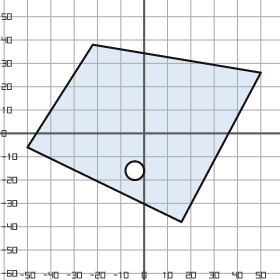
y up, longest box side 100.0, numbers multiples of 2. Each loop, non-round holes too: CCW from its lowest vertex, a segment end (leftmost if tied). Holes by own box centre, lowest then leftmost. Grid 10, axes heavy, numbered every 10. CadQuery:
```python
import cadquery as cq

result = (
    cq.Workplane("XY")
    .moveTo(16.0, -38.0)
    .lineTo(50.0, 26.0)
    .lineTo(-22.0, 38.0)
    .lineTo(-50.0, -6.0)
    .close()
    .moveTo(-4.0, -16.0)
    .circle(4.0)
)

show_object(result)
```